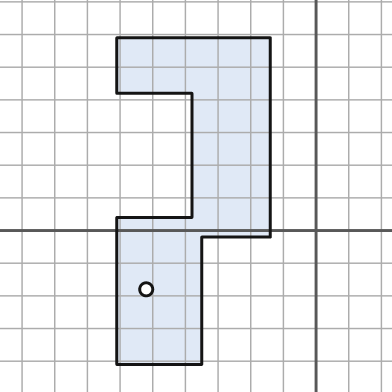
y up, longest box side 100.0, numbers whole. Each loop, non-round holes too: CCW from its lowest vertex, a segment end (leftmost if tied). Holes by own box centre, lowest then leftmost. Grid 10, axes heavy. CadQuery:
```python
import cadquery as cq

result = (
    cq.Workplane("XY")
    .moveTo(-61.0, -41.0)
    .lineTo(-35.0, -41.0)
    .lineTo(-35.0, -2.0)
    .lineTo(-14.0, -2.0)
    .lineTo(-14.0, 59.0)
    .lineTo(-61.0, 59.0)
    .lineTo(-61.0, 42.0)
    .lineTo(-38.0, 42.0)
    .lineTo(-38.0, 4.0)
    .lineTo(-61.0, 4.0)
    .close()
    .moveTo(-52.0, -18.0)
    .circle(2.0)
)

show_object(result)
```